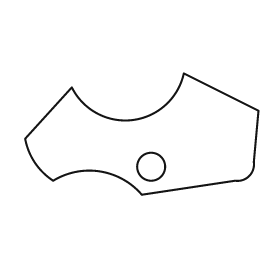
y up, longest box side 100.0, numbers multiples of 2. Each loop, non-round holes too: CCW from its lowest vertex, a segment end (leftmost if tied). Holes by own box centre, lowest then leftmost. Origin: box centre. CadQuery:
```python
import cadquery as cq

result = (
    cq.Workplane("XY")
    .moveTo(0.0, -26.0)
    .lineTo(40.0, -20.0)
    .threePointArc((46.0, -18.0), (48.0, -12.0))
    .lineTo(50.0, 10.0)
    .lineTo(18.0, 26.0)
    .threePointArc((-4.0, 6.0), (-30.0, 20.0))
    .lineTo(-50.0, -2.0)
    .threePointArc((-46.0, -12.0), (-38.0, -20.0))
    .threePointArc((-18.0, -16.0), (0.0, -26.0))
    .close()
    .moveTo(4.0, -14.0)
    .circle(6.0)
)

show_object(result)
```